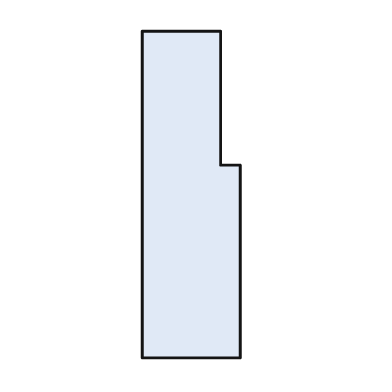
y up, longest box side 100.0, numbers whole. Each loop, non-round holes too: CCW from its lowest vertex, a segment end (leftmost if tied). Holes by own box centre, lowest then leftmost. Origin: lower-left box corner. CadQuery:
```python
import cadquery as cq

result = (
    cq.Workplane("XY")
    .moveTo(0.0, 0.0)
    .lineTo(30.0, 0.0)
    .lineTo(30.0, 59.0)
    .lineTo(24.0, 59.0)
    .lineTo(24.0, 100.0)
    .lineTo(0.0, 100.0)
    .close()
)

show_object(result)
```